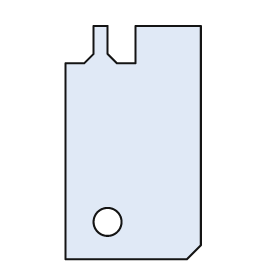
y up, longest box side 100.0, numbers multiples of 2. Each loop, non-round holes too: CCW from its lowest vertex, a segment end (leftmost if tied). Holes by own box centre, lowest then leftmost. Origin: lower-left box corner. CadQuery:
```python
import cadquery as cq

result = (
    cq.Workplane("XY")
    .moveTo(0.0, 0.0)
    .lineTo(52.0, 0.0)
    .lineTo(58.0, 6.0)
    .lineTo(58.0, 100.0)
    .lineTo(30.0, 100.0)
    .lineTo(30.0, 84.0)
    .lineTo(22.0, 84.0)
    .lineTo(18.0, 88.0)
    .lineTo(18.0, 100.0)
    .lineTo(12.0, 100.0)
    .lineTo(12.0, 88.0)
    .lineTo(8.0, 84.0)
    .lineTo(0.0, 84.0)
    .close()
    .moveTo(18.0, 16.0)
    .circle(6.0)
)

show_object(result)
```